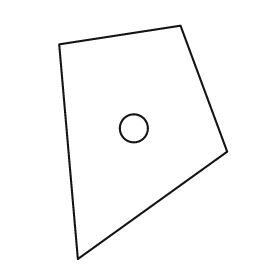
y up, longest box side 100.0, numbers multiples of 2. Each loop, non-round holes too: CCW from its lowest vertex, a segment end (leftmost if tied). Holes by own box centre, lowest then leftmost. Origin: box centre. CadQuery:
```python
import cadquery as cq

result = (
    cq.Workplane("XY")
    .moveTo(-28.0, -50.0)
    .lineTo(36.0, -4.0)
    .lineTo(16.0, 50.0)
    .lineTo(-36.0, 42.0)
    .close()
    .moveTo(-4.0, 6.0)
    .circle(6.0)
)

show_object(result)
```